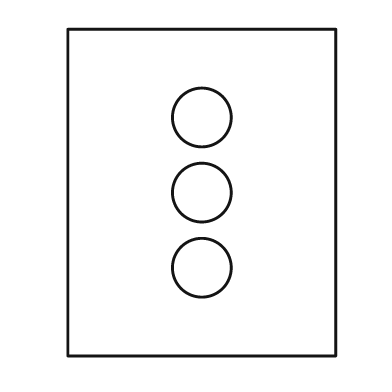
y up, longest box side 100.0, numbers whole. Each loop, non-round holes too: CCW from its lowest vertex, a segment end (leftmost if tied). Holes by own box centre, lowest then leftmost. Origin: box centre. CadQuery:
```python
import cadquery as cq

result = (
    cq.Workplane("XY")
    .moveTo(-41.0, -50.0)
    .lineTo(41.0, -50.0)
    .lineTo(41.0, 50.0)
    .lineTo(-41.0, 50.0)
    .close()
    .moveTo(0.0, -23.0)
    .circle(9.0)
    .moveTo(0.0, 0.0)
    .circle(9.0)
    .moveTo(0.0, 23.0)
    .circle(9.0)
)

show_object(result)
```